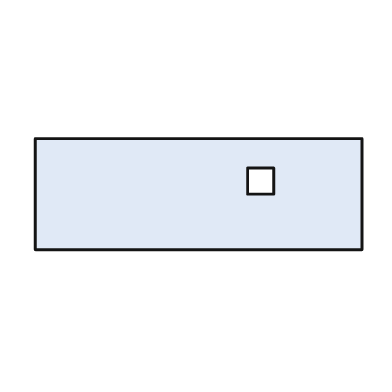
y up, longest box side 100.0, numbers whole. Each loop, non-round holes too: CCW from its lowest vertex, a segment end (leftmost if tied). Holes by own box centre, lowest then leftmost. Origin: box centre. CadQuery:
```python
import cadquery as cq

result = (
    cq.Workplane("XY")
    .moveTo(-50.0, -17.0)
    .lineTo(50.0, -17.0)
    .lineTo(50.0, 17.0)
    .lineTo(-50.0, 17.0)
    .close()
    .moveTo(15.0, 0.0)
    .lineTo(23.0, 0.0)
    .lineTo(23.0, 8.0)
    .lineTo(15.0, 8.0)
    .close()
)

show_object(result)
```